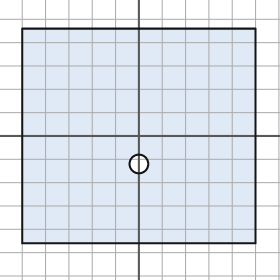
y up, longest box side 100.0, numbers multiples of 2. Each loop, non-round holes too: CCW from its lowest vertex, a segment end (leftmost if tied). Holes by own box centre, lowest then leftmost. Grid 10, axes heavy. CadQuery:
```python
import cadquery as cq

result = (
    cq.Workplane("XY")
    .moveTo(-50.0, -46.0)
    .lineTo(50.0, -46.0)
    .lineTo(50.0, 46.0)
    .lineTo(-50.0, 46.0)
    .close()
    .moveTo(0.0, -12.0)
    .circle(4.0)
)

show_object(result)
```